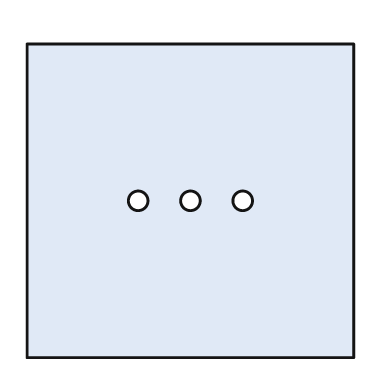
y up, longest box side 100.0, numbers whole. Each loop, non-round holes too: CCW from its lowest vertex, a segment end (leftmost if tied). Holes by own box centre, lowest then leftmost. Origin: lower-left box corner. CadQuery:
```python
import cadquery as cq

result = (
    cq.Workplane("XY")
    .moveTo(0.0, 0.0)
    .lineTo(100.0, 0.0)
    .lineTo(100.0, 96.0)
    .lineTo(0.0, 96.0)
    .close()
    .moveTo(34.0, 48.0)
    .circle(3.0)
    .moveTo(50.0, 48.0)
    .circle(3.0)
    .moveTo(66.0, 48.0)
    .circle(3.0)
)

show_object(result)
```